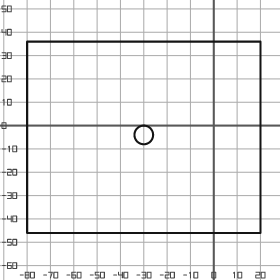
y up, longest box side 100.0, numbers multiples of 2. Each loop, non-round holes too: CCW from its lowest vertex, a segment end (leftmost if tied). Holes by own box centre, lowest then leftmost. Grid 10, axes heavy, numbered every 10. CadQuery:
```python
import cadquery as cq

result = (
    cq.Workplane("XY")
    .moveTo(-80.0, -46.0)
    .lineTo(20.0, -46.0)
    .lineTo(20.0, 36.0)
    .lineTo(-80.0, 36.0)
    .close()
    .moveTo(-30.0, -4.0)
    .circle(4.0)
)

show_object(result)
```